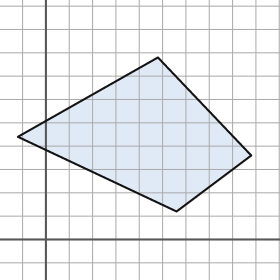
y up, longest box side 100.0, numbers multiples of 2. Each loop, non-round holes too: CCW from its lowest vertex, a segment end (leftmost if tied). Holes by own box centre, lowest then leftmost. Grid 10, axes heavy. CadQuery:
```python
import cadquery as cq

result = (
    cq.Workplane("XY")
    .moveTo(56.0, 12.0)
    .lineTo(88.0, 36.0)
    .lineTo(48.0, 78.0)
    .lineTo(-12.0, 44.0)
    .close()
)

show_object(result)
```